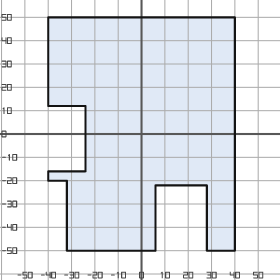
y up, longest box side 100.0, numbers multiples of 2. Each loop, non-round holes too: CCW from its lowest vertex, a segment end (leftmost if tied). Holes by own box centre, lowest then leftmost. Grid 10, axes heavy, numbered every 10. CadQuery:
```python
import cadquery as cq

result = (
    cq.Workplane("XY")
    .moveTo(-32.0, -50.0)
    .lineTo(6.0, -50.0)
    .lineTo(6.0, -22.0)
    .lineTo(28.0, -22.0)
    .lineTo(28.0, -50.0)
    .lineTo(40.0, -50.0)
    .lineTo(40.0, 50.0)
    .lineTo(-40.0, 50.0)
    .lineTo(-40.0, 12.0)
    .lineTo(-24.0, 12.0)
    .lineTo(-24.0, -16.0)
    .lineTo(-40.0, -16.0)
    .lineTo(-40.0, -20.0)
    .lineTo(-32.0, -20.0)
    .close()
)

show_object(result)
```